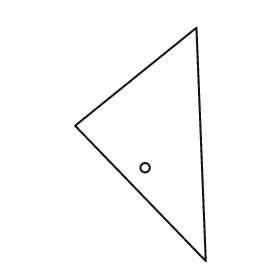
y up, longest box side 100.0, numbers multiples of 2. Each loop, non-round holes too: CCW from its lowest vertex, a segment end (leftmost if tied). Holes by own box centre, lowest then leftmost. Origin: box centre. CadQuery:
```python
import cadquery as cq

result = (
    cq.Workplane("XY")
    .moveTo(28.0, -50.0)
    .lineTo(24.0, 50.0)
    .lineTo(-28.0, 8.0)
    .close()
    .moveTo(2.0, -10.0)
    .circle(2.0)
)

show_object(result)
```